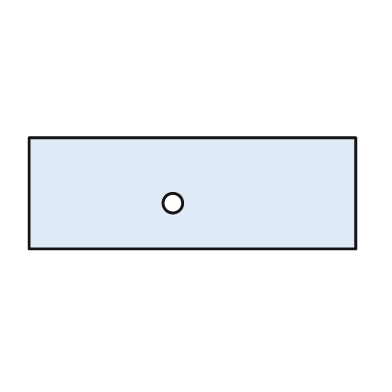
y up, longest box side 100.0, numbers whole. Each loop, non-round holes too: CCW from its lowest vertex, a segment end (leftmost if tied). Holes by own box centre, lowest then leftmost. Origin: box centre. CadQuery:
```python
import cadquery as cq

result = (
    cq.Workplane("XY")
    .moveTo(-50.0, -17.0)
    .lineTo(50.0, -17.0)
    .lineTo(50.0, 17.0)
    .lineTo(-50.0, 17.0)
    .close()
    .moveTo(-6.0, -3.0)
    .circle(3.0)
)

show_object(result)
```